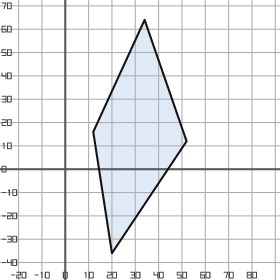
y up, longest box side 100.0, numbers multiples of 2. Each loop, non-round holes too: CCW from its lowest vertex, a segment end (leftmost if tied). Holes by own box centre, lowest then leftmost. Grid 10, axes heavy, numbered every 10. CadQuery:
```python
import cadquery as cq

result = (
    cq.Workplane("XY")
    .moveTo(20.0, -36.0)
    .lineTo(52.0, 12.0)
    .lineTo(34.0, 64.0)
    .lineTo(12.0, 16.0)
    .close()
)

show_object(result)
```